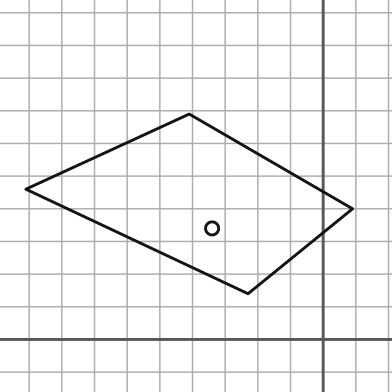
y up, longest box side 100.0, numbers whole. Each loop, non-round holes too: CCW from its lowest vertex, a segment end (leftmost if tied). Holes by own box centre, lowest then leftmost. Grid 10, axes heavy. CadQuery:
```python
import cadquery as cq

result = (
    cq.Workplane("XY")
    .moveTo(-23.0, 14.0)
    .lineTo(9.0, 40.0)
    .lineTo(-41.0, 69.0)
    .lineTo(-91.0, 46.0)
    .close()
    .moveTo(-34.0, 34.0)
    .circle(2.0)
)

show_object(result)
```